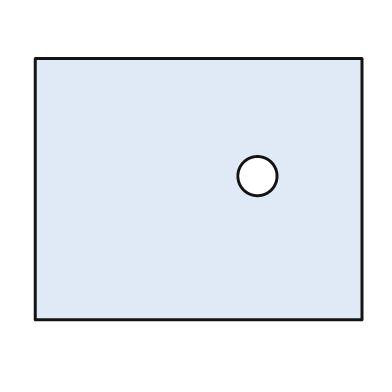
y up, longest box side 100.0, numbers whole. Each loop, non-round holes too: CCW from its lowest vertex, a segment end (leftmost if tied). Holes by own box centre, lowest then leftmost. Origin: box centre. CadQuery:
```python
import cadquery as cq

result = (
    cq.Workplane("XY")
    .moveTo(-50.0, -40.0)
    .lineTo(50.0, -40.0)
    .lineTo(50.0, 40.0)
    .lineTo(-50.0, 40.0)
    .close()
    .moveTo(18.0, 4.0)
    .circle(6.0)
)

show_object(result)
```